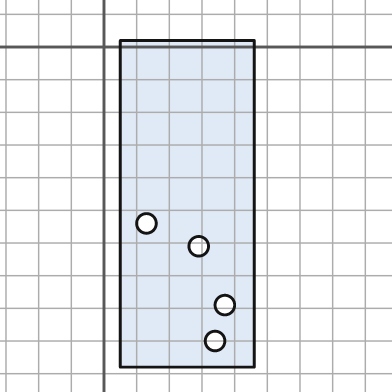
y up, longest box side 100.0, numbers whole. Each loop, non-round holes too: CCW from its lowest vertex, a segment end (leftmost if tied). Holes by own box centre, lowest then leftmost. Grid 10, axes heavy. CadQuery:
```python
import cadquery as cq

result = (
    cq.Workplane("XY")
    .moveTo(5.0, -98.0)
    .lineTo(46.0, -98.0)
    .lineTo(46.0, 2.0)
    .lineTo(5.0, 2.0)
    .close()
    .moveTo(34.0, -90.0)
    .circle(3.0)
    .moveTo(37.0, -79.0)
    .circle(3.0)
    .moveTo(29.0, -61.0)
    .circle(3.0)
    .moveTo(13.0, -54.0)
    .circle(3.0)
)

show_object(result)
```